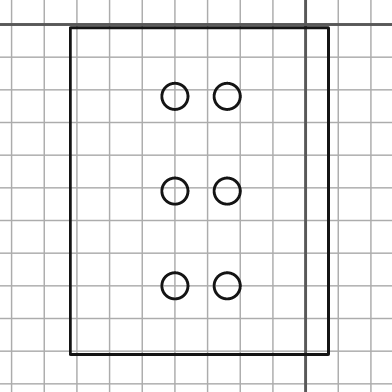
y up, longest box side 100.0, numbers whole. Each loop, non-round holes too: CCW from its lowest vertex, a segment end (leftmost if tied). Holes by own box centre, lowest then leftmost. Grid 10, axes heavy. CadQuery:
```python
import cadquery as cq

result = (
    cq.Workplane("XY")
    .moveTo(-72.0, -101.0)
    .lineTo(7.0, -101.0)
    .lineTo(7.0, -1.0)
    .lineTo(-72.0, -1.0)
    .close()
    .moveTo(-40.0, -80.0)
    .circle(4.0)
    .moveTo(-24.0, -80.0)
    .circle(4.0)
    .moveTo(-40.0, -51.0)
    .circle(4.0)
    .moveTo(-24.0, -51.0)
    .circle(4.0)
    .moveTo(-40.0, -22.0)
    .circle(4.0)
    .moveTo(-24.0, -22.0)
    .circle(4.0)
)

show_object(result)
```